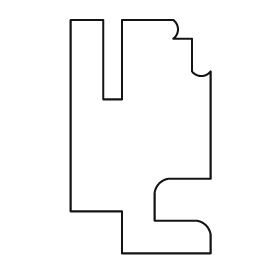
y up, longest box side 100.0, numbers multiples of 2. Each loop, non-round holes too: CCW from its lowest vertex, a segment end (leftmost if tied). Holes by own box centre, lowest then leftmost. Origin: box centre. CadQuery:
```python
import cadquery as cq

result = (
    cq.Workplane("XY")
    .moveTo(-8.0, -50.0)
    .lineTo(30.0, -50.0)
    .lineTo(30.0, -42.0)
    .threePointArc((28.0, -38.0), (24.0, -36.0))
    .lineTo(6.0, -36.0)
    .lineTo(6.0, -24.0)
    .threePointArc((8.0, -20.0), (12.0, -18.0))
    .lineTo(30.0, -18.0)
    .lineTo(30.0, 28.0)
    .threePointArc((26.0, 26.0), (22.0, 28.0))
    .lineTo(22.0, 42.0)
    .lineTo(14.0, 42.0)
    .threePointArc((16.0, 46.0), (14.0, 50.0))
    .lineTo(-8.0, 50.0)
    .lineTo(-8.0, 16.0)
    .lineTo(-16.0, 16.0)
    .lineTo(-16.0, 50.0)
    .lineTo(-30.0, 50.0)
    .lineTo(-30.0, -32.0)
    .lineTo(-8.0, -32.0)
    .close()
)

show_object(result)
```